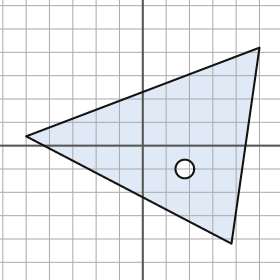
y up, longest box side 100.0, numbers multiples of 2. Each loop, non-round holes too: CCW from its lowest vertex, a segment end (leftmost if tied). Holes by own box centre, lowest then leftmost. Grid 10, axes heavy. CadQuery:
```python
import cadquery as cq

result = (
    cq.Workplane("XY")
    .moveTo(38.0, -42.0)
    .lineTo(50.0, 42.0)
    .lineTo(-50.0, 4.0)
    .close()
    .moveTo(18.0, -10.0)
    .circle(4.0)
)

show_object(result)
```